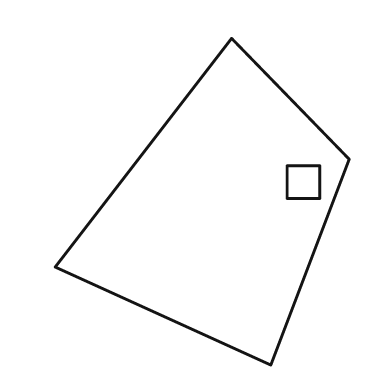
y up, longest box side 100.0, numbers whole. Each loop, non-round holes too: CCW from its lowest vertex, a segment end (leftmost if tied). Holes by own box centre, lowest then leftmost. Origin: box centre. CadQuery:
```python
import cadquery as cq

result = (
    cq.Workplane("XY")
    .moveTo(21.0, -50.0)
    .lineTo(45.0, 13.0)
    .lineTo(9.0, 50.0)
    .lineTo(-45.0, -20.0)
    .close()
    .moveTo(26.0, 1.0)
    .lineTo(36.0, 1.0)
    .lineTo(36.0, 11.0)
    .lineTo(26.0, 11.0)
    .close()
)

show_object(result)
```